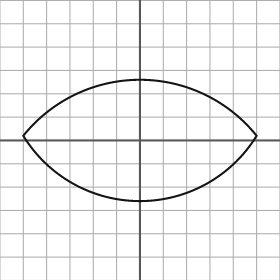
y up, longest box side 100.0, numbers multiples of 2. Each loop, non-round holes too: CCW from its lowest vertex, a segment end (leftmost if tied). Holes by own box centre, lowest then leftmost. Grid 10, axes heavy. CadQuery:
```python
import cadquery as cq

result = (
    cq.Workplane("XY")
    .moveTo(-50.0, 2.0)
    .threePointArc((0.0, -26.0), (50.0, 2.0))
    .threePointArc((0.0, 26.0), (-50.0, 2.0))
    .close()
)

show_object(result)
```